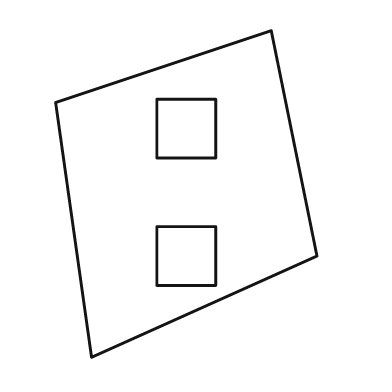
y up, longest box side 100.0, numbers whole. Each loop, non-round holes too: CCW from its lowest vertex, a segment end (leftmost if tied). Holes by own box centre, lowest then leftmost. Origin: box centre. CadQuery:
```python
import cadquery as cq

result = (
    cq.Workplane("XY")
    .moveTo(-29.0, -50.0)
    .lineTo(40.0, -19.0)
    .lineTo(26.0, 50.0)
    .lineTo(-40.0, 28.0)
    .close()
    .moveTo(-9.0, -28.0)
    .lineTo(9.0, -28.0)
    .lineTo(9.0, -10.0)
    .lineTo(-9.0, -10.0)
    .close()
    .moveTo(-9.0, 11.0)
    .lineTo(9.0, 11.0)
    .lineTo(9.0, 29.0)
    .lineTo(-9.0, 29.0)
    .close()
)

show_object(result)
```